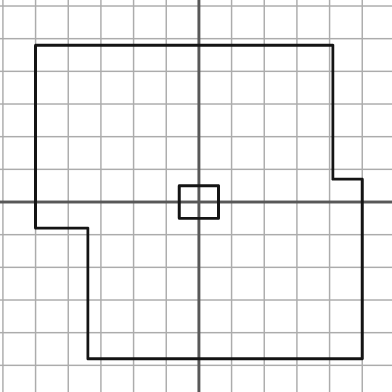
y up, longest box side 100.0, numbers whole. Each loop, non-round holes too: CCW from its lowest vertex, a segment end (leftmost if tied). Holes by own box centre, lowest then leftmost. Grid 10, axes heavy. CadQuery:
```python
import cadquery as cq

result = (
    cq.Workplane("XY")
    .moveTo(-34.0, -48.0)
    .lineTo(50.0, -48.0)
    .lineTo(50.0, 7.0)
    .lineTo(41.0, 7.0)
    .lineTo(41.0, 48.0)
    .lineTo(-50.0, 48.0)
    .lineTo(-50.0, -8.0)
    .lineTo(-34.0, -8.0)
    .close()
    .moveTo(-6.0, -5.0)
    .lineTo(6.0, -5.0)
    .lineTo(6.0, 5.0)
    .lineTo(-6.0, 5.0)
    .close()
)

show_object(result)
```